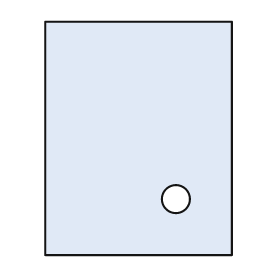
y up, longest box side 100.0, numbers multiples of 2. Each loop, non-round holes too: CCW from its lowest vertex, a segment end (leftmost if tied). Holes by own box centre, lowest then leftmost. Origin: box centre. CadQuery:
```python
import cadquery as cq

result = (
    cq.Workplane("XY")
    .moveTo(-40.0, -50.0)
    .lineTo(40.0, -50.0)
    .lineTo(40.0, 50.0)
    .lineTo(-40.0, 50.0)
    .close()
    .moveTo(16.0, -26.0)
    .circle(6.0)
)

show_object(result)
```